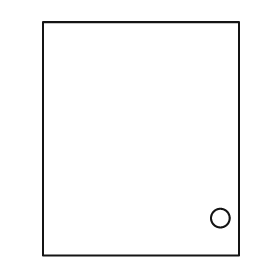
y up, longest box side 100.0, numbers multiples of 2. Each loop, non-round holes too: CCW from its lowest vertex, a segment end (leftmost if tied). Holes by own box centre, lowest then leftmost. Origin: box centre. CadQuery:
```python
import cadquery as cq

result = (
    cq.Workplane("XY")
    .moveTo(-42.0, -50.0)
    .lineTo(42.0, -50.0)
    .lineTo(42.0, 50.0)
    .lineTo(-42.0, 50.0)
    .close()
    .moveTo(34.0, -34.0)
    .circle(4.0)
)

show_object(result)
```